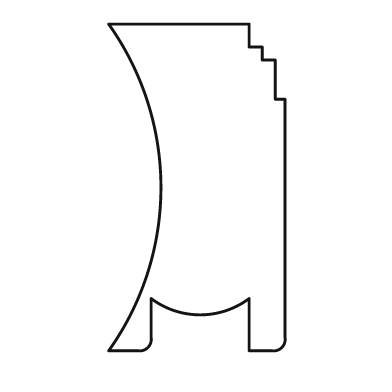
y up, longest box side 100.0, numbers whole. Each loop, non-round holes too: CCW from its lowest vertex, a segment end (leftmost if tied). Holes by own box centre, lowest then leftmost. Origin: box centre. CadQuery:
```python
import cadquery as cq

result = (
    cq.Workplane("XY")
    .moveTo(-27.0, -50.0)
    .lineTo(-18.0, -50.0)
    .threePointArc((-15.0, -49.0), (-14.0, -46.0))
    .lineTo(-14.0, -34.0)
    .threePointArc((1.0, -39.0), (16.0, -34.0))
    .lineTo(16.0, -50.0)
    .lineTo(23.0, -50.0)
    .threePointArc((26.0, -49.0), (27.0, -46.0))
    .lineTo(27.0, 27.0)
    .lineTo(24.0, 27.0)
    .lineTo(24.0, 39.0)
    .lineTo(20.0, 39.0)
    .lineTo(20.0, 43.0)
    .lineTo(16.0, 43.0)
    .lineTo(16.0, 50.0)
    .lineTo(-27.0, 50.0)
    .threePointArc((-11.0, 0.0), (-27.0, -50.0))
    .close()
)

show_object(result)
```